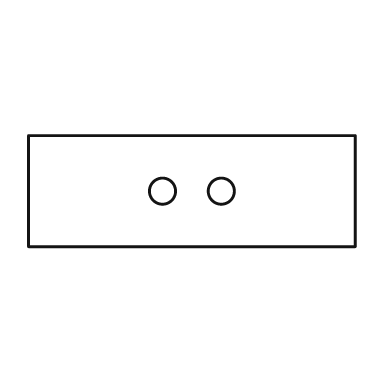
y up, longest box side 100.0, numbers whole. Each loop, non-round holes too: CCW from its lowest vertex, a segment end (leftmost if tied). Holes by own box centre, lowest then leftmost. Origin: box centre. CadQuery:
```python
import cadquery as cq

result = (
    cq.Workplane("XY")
    .moveTo(-50.0, -17.0)
    .lineTo(50.0, -17.0)
    .lineTo(50.0, 17.0)
    .lineTo(-50.0, 17.0)
    .close()
    .moveTo(-9.0, 0.0)
    .circle(4.0)
    .moveTo(9.0, 0.0)
    .circle(4.0)
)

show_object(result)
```